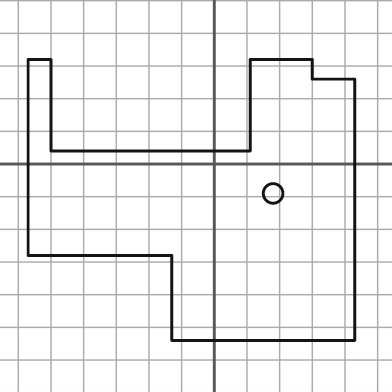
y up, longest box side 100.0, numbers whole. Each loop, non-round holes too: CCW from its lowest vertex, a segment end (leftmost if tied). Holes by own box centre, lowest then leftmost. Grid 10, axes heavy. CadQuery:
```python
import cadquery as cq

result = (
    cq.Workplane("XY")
    .moveTo(-13.0, -54.0)
    .lineTo(43.0, -54.0)
    .lineTo(43.0, 26.0)
    .lineTo(30.0, 26.0)
    .lineTo(30.0, 32.0)
    .lineTo(11.0, 32.0)
    .lineTo(11.0, 4.0)
    .lineTo(-50.0, 4.0)
    .lineTo(-50.0, 32.0)
    .lineTo(-57.0, 32.0)
    .lineTo(-57.0, -28.0)
    .lineTo(-13.0, -28.0)
    .close()
    .moveTo(18.0, -9.0)
    .circle(3.0)
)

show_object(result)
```